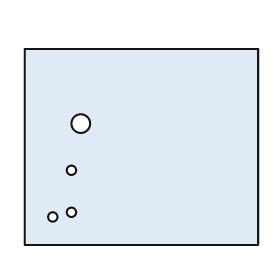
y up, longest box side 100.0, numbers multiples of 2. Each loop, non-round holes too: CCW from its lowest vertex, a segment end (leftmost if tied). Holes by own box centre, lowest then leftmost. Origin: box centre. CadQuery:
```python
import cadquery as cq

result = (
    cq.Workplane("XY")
    .moveTo(-50.0, -42.0)
    .lineTo(50.0, -42.0)
    .lineTo(50.0, 42.0)
    .lineTo(-50.0, 42.0)
    .close()
    .moveTo(-38.0, -30.0)
    .circle(2.0)
    .moveTo(-30.0, -28.0)
    .circle(2.0)
    .moveTo(-30.0, -10.0)
    .circle(2.0)
    .moveTo(-26.0, 10.0)
    .circle(4.0)
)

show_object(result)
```